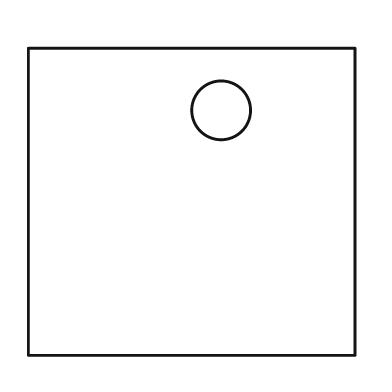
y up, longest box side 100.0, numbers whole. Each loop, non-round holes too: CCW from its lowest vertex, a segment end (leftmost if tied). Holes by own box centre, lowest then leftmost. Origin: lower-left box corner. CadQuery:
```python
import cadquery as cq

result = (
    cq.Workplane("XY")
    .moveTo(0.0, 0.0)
    .lineTo(100.0, 0.0)
    .lineTo(100.0, 94.0)
    .lineTo(0.0, 94.0)
    .close()
    .moveTo(59.0, 75.0)
    .circle(9.0)
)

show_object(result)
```